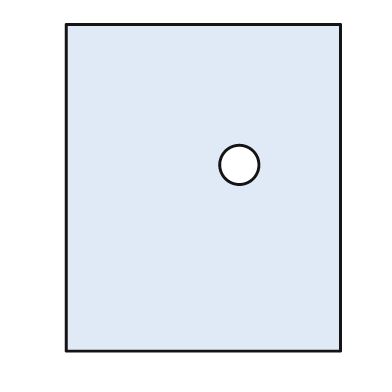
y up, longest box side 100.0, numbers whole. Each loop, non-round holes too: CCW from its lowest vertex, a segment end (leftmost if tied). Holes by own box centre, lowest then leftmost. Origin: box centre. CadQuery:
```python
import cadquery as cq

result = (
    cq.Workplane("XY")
    .moveTo(-42.0, -50.0)
    .lineTo(42.0, -50.0)
    .lineTo(42.0, 50.0)
    .lineTo(-42.0, 50.0)
    .close()
    .moveTo(11.0, 7.0)
    .circle(6.0)
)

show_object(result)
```